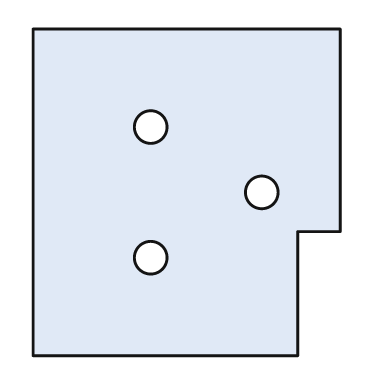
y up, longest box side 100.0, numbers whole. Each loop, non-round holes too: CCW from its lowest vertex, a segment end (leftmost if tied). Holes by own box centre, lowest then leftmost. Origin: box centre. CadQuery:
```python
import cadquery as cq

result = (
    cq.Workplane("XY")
    .moveTo(-47.0, -50.0)
    .lineTo(34.0, -50.0)
    .lineTo(34.0, -12.0)
    .lineTo(47.0, -12.0)
    .lineTo(47.0, 50.0)
    .lineTo(-47.0, 50.0)
    .close()
    .moveTo(-11.0, -20.0)
    .circle(5.0)
    .moveTo(23.0, 0.0)
    .circle(5.0)
    .moveTo(-11.0, 20.0)
    .circle(5.0)
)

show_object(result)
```